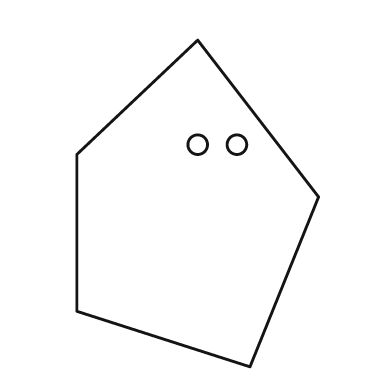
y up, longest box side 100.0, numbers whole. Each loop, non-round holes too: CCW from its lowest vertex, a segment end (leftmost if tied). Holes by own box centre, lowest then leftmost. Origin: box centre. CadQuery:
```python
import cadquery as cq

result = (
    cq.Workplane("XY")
    .moveTo(16.0, -50.0)
    .lineTo(37.0, 2.0)
    .lineTo(0.0, 50.0)
    .lineTo(-37.0, 15.0)
    .lineTo(-37.0, -33.0)
    .close()
    .moveTo(0.0, 18.0)
    .circle(3.0)
    .moveTo(12.0, 18.0)
    .circle(3.0)
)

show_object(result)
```